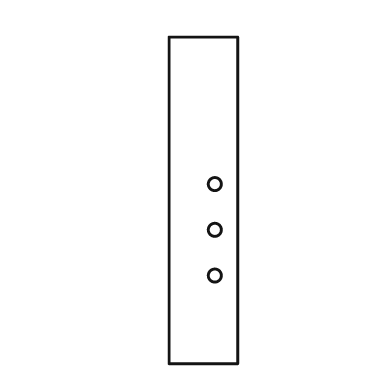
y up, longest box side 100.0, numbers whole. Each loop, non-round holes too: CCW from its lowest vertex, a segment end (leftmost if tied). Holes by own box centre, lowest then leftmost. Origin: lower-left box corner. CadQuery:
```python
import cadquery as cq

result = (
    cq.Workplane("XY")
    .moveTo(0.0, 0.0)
    .lineTo(21.0, 0.0)
    .lineTo(21.0, 100.0)
    .lineTo(0.0, 100.0)
    .close()
    .moveTo(14.0, 27.0)
    .circle(2.0)
    .moveTo(14.0, 41.0)
    .circle(2.0)
    .moveTo(14.0, 55.0)
    .circle(2.0)
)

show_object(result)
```